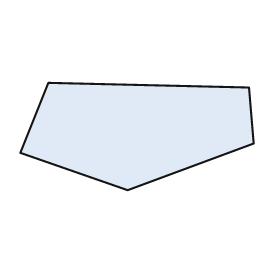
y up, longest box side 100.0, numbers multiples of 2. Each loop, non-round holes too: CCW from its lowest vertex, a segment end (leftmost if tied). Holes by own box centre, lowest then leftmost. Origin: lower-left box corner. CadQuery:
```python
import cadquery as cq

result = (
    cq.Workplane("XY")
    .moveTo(46.0, 0.0)
    .lineTo(100.0, 20.0)
    .lineTo(98.0, 44.0)
    .lineTo(12.0, 46.0)
    .lineTo(0.0, 16.0)
    .close()
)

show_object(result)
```